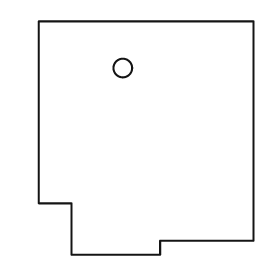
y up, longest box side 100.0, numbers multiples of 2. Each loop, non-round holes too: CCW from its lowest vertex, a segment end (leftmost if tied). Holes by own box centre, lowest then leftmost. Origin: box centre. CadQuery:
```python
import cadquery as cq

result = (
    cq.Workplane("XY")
    .moveTo(-32.0, -50.0)
    .lineTo(6.0, -50.0)
    .lineTo(6.0, -44.0)
    .lineTo(46.0, -44.0)
    .lineTo(46.0, 50.0)
    .lineTo(-46.0, 50.0)
    .lineTo(-46.0, -28.0)
    .lineTo(-32.0, -28.0)
    .close()
    .moveTo(-10.0, 30.0)
    .circle(4.0)
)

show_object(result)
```